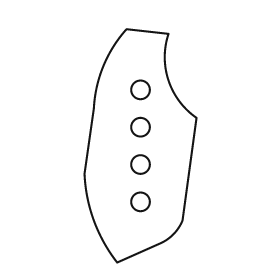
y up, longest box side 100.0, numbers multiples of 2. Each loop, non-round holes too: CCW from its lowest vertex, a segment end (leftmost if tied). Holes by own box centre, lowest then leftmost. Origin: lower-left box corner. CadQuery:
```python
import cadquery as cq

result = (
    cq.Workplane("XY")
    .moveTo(14.0, 0.0)
    .lineTo(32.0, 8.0)
    .threePointArc((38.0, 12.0), (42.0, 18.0))
    .lineTo(48.0, 62.0)
    .threePointArc((36.0, 78.0), (36.0, 98.0))
    .lineTo(18.0, 100.0)
    .threePointArc((8.0, 84.0), (4.0, 66.0))
    .lineTo(0.0, 38.0)
    .threePointArc((4.0, 18.0), (14.0, 0.0))
    .close()
    .moveTo(24.0, 26.0)
    .circle(4.0)
    .moveTo(24.0, 42.0)
    .circle(4.0)
    .moveTo(24.0, 58.0)
    .circle(4.0)
    .moveTo(24.0, 74.0)
    .circle(4.0)
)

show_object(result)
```